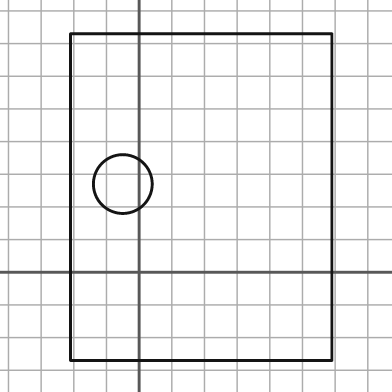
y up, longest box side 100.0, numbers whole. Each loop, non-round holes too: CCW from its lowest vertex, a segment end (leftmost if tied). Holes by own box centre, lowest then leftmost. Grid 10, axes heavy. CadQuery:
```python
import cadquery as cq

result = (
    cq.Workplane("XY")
    .moveTo(-21.0, -27.0)
    .lineTo(59.0, -27.0)
    .lineTo(59.0, 73.0)
    .lineTo(-21.0, 73.0)
    .close()
    .moveTo(-5.0, 27.0)
    .circle(9.0)
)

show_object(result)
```